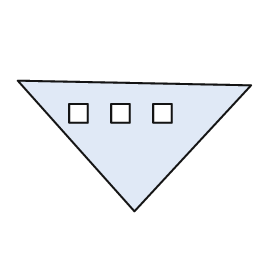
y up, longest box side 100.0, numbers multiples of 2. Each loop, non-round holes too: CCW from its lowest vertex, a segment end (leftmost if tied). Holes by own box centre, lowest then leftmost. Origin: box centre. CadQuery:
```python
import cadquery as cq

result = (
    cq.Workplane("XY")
    .moveTo(0.0, -28.0)
    .lineTo(50.0, 26.0)
    .lineTo(-50.0, 28.0)
    .close()
    .moveTo(-28.0, 10.0)
    .lineTo(-20.0, 10.0)
    .lineTo(-20.0, 18.0)
    .lineTo(-28.0, 18.0)
    .close()
    .moveTo(-10.0, 10.0)
    .lineTo(-2.0, 10.0)
    .lineTo(-2.0, 18.0)
    .lineTo(-10.0, 18.0)
    .close()
    .moveTo(8.0, 10.0)
    .lineTo(16.0, 10.0)
    .lineTo(16.0, 18.0)
    .lineTo(8.0, 18.0)
    .close()
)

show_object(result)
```